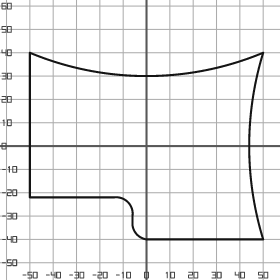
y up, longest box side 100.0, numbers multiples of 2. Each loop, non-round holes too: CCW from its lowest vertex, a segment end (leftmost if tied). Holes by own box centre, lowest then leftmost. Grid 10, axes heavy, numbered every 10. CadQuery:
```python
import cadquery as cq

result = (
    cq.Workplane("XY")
    .moveTo(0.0, -40.0)
    .lineTo(50.0, -40.0)
    .threePointArc((44.0, 0.0), (50.0, 40.0))
    .threePointArc((0.0, 30.0), (-50.0, 40.0))
    .lineTo(-50.0, -22.0)
    .lineTo(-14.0, -22.0)
    .threePointArc((-8.0, -24.0), (-6.0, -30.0))
    .lineTo(-6.0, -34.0)
    .threePointArc((-4.0, -38.0), (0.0, -40.0))
    .close()
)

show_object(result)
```